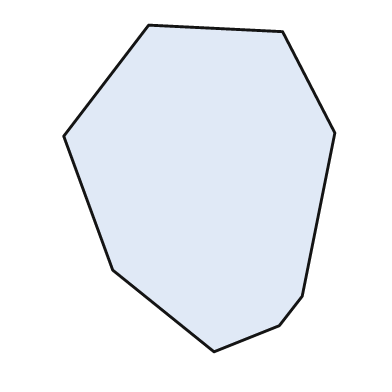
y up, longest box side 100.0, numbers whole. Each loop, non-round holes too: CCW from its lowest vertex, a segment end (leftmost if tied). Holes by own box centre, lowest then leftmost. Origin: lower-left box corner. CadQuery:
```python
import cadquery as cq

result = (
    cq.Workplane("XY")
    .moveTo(46.0, 0.0)
    .lineTo(66.0, 8.0)
    .lineTo(73.0, 17.0)
    .lineTo(83.0, 67.0)
    .lineTo(67.0, 98.0)
    .lineTo(26.0, 100.0)
    .lineTo(0.0, 66.0)
    .lineTo(15.0, 25.0)
    .close()
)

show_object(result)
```